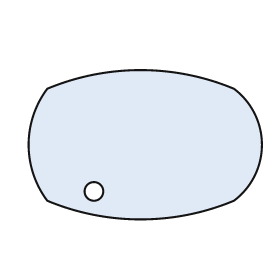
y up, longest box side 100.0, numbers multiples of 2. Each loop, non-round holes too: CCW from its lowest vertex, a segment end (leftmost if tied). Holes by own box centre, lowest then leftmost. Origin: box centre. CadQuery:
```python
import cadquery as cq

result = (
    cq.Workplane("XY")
    .moveTo(-42.0, -24.0)
    .threePointArc((-2.0, -32.0), (38.0, -24.0))
    .threePointArc((50.0, 0.0), (38.0, 24.0))
    .threePointArc((-2.0, 32.0), (-42.0, 24.0))
    .threePointArc((-50.0, 0.0), (-42.0, -24.0))
    .close()
    .moveTo(-22.0, -20.0)
    .circle(4.0)
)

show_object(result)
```